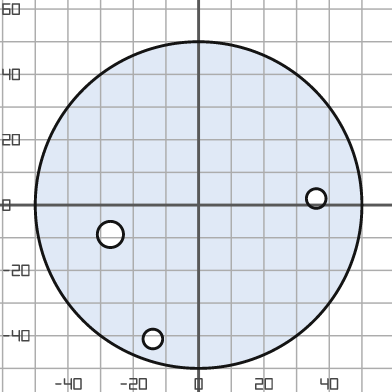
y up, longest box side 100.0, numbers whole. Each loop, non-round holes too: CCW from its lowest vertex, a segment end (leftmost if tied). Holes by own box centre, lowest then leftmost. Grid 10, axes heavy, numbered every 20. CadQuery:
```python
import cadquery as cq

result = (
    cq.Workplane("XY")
    .moveTo(0.0, 0.0)
    .circle(50.0)
    .moveTo(-14.0, -41.0)
    .circle(3.0)
    .moveTo(-27.0, -9.0)
    .circle(4.0)
    .moveTo(36.0, 2.0)
    .circle(3.0)
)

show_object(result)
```